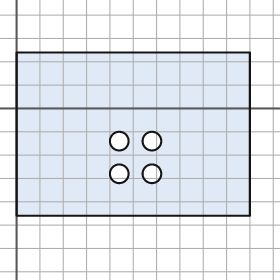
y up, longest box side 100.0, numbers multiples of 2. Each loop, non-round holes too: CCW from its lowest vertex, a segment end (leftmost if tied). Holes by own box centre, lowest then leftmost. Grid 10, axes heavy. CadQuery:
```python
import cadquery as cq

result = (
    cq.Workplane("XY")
    .moveTo(0.0, -46.0)
    .lineTo(100.0, -46.0)
    .lineTo(100.0, 24.0)
    .lineTo(0.0, 24.0)
    .close()
    .moveTo(44.0, -28.0)
    .circle(4.0)
    .moveTo(58.0, -28.0)
    .circle(4.0)
    .moveTo(44.0, -14.0)
    .circle(4.0)
    .moveTo(58.0, -14.0)
    .circle(4.0)
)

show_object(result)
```